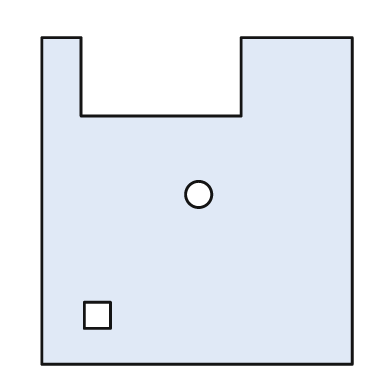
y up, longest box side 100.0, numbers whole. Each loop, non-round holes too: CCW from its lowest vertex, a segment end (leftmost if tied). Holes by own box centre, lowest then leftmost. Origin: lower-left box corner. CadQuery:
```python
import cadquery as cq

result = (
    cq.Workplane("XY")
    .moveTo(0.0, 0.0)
    .lineTo(95.0, 0.0)
    .lineTo(95.0, 100.0)
    .lineTo(61.0, 100.0)
    .lineTo(61.0, 76.0)
    .lineTo(12.0, 76.0)
    .lineTo(12.0, 100.0)
    .lineTo(0.0, 100.0)
    .close()
    .moveTo(13.0, 11.0)
    .lineTo(21.0, 11.0)
    .lineTo(21.0, 19.0)
    .lineTo(13.0, 19.0)
    .close()
    .moveTo(48.0, 52.0)
    .circle(4.0)
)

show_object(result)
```